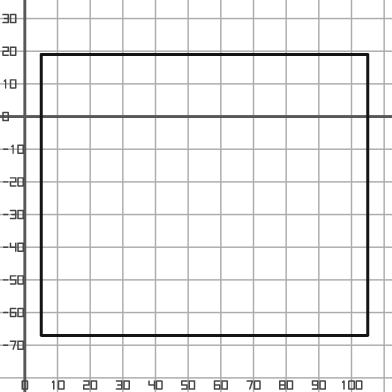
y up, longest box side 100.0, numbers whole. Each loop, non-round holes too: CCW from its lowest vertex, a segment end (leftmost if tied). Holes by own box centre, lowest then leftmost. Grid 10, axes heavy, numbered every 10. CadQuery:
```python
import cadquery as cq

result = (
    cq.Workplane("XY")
    .moveTo(5.0, -67.0)
    .lineTo(105.0, -67.0)
    .lineTo(105.0, 19.0)
    .lineTo(5.0, 19.0)
    .close()
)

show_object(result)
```